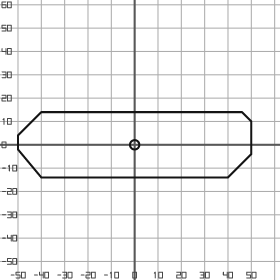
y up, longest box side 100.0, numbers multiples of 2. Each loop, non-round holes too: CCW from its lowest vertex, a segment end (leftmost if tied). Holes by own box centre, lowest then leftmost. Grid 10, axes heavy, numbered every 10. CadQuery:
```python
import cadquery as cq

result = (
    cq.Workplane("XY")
    .moveTo(-40.0, -14.0)
    .lineTo(40.0, -14.0)
    .lineTo(50.0, -4.0)
    .lineTo(50.0, 10.0)
    .lineTo(46.0, 14.0)
    .lineTo(-40.0, 14.0)
    .lineTo(-50.0, 4.0)
    .lineTo(-50.0, -2.0)
    .close()
    .moveTo(0.0, 0.0)
    .circle(2.0)
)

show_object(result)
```